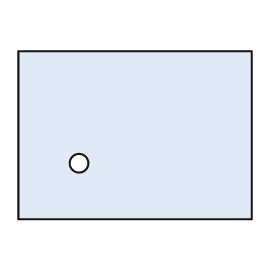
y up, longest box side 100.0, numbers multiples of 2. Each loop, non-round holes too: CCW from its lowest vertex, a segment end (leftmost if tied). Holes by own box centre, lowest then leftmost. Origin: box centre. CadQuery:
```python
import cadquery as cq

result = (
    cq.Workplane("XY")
    .moveTo(-50.0, -36.0)
    .lineTo(50.0, -36.0)
    .lineTo(50.0, 36.0)
    .lineTo(-50.0, 36.0)
    .close()
    .moveTo(-24.0, -12.0)
    .circle(4.0)
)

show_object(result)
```